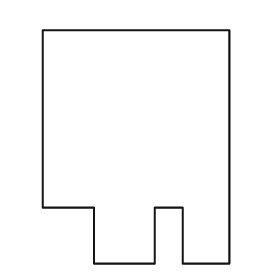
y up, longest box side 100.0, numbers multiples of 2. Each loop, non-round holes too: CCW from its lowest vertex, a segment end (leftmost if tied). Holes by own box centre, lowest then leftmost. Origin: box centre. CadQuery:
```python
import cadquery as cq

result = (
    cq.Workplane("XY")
    .moveTo(-18.0, -50.0)
    .lineTo(8.0, -50.0)
    .lineTo(8.0, -26.0)
    .lineTo(20.0, -26.0)
    .lineTo(20.0, -50.0)
    .lineTo(40.0, -50.0)
    .lineTo(40.0, 50.0)
    .lineTo(-40.0, 50.0)
    .lineTo(-40.0, -26.0)
    .lineTo(-18.0, -26.0)
    .close()
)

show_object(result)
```